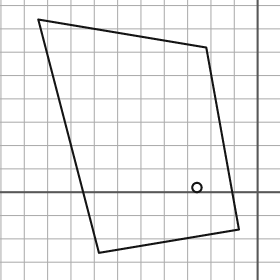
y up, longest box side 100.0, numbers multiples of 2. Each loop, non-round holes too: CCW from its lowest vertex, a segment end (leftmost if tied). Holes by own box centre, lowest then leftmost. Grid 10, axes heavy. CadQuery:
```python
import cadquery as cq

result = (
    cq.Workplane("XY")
    .moveTo(-68.0, -26.0)
    .lineTo(-8.0, -16.0)
    .lineTo(-22.0, 62.0)
    .lineTo(-94.0, 74.0)
    .close()
    .moveTo(-26.0, 2.0)
    .circle(2.0)
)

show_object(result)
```